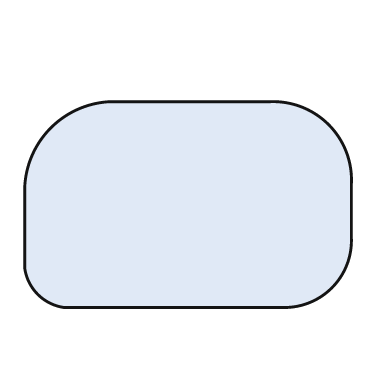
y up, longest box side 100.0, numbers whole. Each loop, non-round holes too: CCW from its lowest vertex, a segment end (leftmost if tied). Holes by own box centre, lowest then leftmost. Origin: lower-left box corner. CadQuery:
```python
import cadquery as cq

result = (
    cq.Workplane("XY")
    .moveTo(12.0, 0.0)
    .lineTo(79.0, 0.0)
    .threePointArc((94.0, 6.0), (100.0, 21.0))
    .lineTo(100.0, 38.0)
    .threePointArc((93.0, 56.0), (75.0, 63.0))
    .lineTo(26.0, 63.0)
    .threePointArc((8.0, 55.0), (0.0, 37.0))
    .lineTo(0.0, 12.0)
    .threePointArc((4.0, 4.0), (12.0, 0.0))
    .close()
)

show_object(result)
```